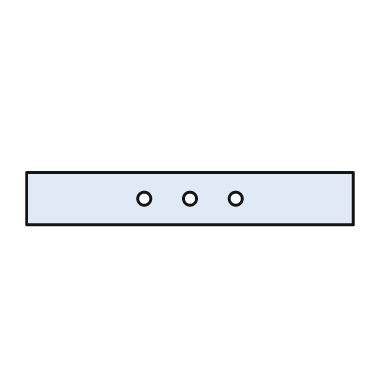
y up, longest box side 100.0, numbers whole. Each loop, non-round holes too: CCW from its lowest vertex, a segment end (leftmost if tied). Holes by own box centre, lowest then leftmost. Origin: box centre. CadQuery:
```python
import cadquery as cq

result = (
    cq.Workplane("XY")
    .moveTo(-50.0, -8.0)
    .lineTo(50.0, -8.0)
    .lineTo(50.0, 8.0)
    .lineTo(-50.0, 8.0)
    .close()
    .moveTo(-14.0, 0.0)
    .circle(2.0)
    .moveTo(0.0, 0.0)
    .circle(2.0)
    .moveTo(14.0, 0.0)
    .circle(2.0)
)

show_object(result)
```